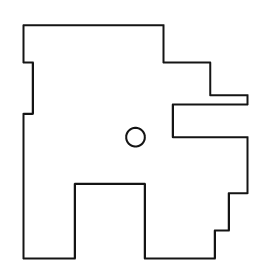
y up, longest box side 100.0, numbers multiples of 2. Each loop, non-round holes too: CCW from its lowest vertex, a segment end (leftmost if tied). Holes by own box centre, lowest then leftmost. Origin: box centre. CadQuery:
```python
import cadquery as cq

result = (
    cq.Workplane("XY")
    .moveTo(-48.0, -50.0)
    .lineTo(-26.0, -50.0)
    .lineTo(-26.0, -18.0)
    .lineTo(4.0, -18.0)
    .lineTo(4.0, -50.0)
    .lineTo(34.0, -50.0)
    .lineTo(34.0, -38.0)
    .lineTo(40.0, -38.0)
    .lineTo(40.0, -22.0)
    .lineTo(48.0, -22.0)
    .lineTo(48.0, 2.0)
    .lineTo(16.0, 2.0)
    .lineTo(16.0, 16.0)
    .lineTo(48.0, 16.0)
    .lineTo(48.0, 20.0)
    .lineTo(32.0, 20.0)
    .lineTo(32.0, 34.0)
    .lineTo(12.0, 34.0)
    .lineTo(12.0, 50.0)
    .lineTo(-48.0, 50.0)
    .lineTo(-48.0, 34.0)
    .lineTo(-44.0, 34.0)
    .lineTo(-44.0, 12.0)
    .lineTo(-48.0, 12.0)
    .close()
    .moveTo(0.0, 2.0)
    .circle(4.0)
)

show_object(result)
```